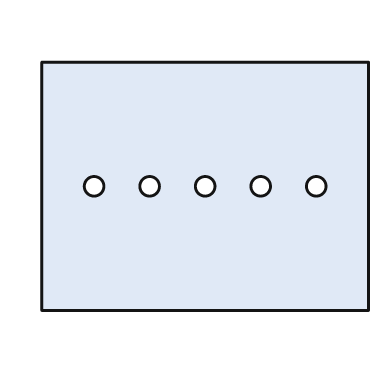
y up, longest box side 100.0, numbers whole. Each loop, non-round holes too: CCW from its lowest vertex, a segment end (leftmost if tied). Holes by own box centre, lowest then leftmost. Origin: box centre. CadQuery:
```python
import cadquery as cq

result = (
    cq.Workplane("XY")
    .moveTo(-50.0, -38.0)
    .lineTo(50.0, -38.0)
    .lineTo(50.0, 38.0)
    .lineTo(-50.0, 38.0)
    .close()
    .moveTo(-34.0, 0.0)
    .circle(3.0)
    .moveTo(-17.0, 0.0)
    .circle(3.0)
    .moveTo(0.0, 0.0)
    .circle(3.0)
    .moveTo(17.0, 0.0)
    .circle(3.0)
    .moveTo(34.0, 0.0)
    .circle(3.0)
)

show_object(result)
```